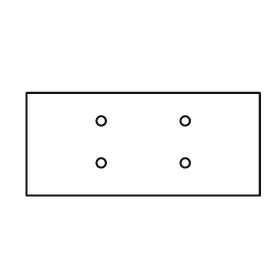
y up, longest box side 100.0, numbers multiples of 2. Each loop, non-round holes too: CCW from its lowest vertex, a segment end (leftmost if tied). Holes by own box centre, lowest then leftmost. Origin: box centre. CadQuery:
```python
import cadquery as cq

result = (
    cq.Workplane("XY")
    .moveTo(-50.0, -22.0)
    .lineTo(50.0, -22.0)
    .lineTo(50.0, 22.0)
    .lineTo(-50.0, 22.0)
    .close()
    .moveTo(-18.0, -8.0)
    .circle(2.0)
    .moveTo(18.0, -8.0)
    .circle(2.0)
    .moveTo(-18.0, 10.0)
    .circle(2.0)
    .moveTo(18.0, 10.0)
    .circle(2.0)
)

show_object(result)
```